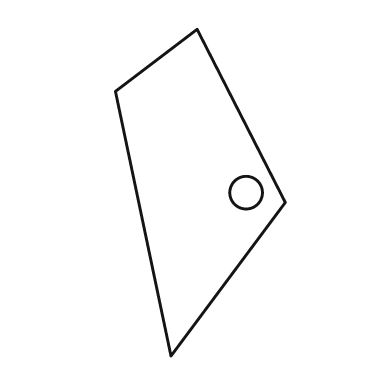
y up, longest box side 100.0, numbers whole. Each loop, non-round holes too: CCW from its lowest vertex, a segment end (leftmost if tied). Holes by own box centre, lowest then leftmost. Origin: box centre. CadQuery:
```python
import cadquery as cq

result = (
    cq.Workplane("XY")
    .moveTo(-9.0, -50.0)
    .lineTo(26.0, -3.0)
    .lineTo(-1.0, 50.0)
    .lineTo(-26.0, 31.0)
    .close()
    .moveTo(14.0, 0.0)
    .circle(5.0)
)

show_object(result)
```